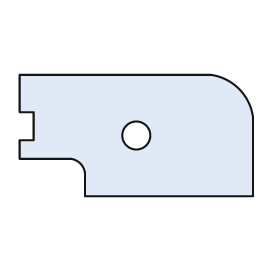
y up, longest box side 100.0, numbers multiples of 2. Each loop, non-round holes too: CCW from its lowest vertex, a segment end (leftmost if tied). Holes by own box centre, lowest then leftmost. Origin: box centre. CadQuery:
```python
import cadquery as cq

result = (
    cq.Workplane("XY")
    .moveTo(-22.0, -26.0)
    .lineTo(50.0, -26.0)
    .lineTo(50.0, 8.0)
    .threePointArc((44.0, 20.0), (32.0, 26.0))
    .lineTo(-50.0, 26.0)
    .lineTo(-50.0, 10.0)
    .lineTo(-44.0, 10.0)
    .lineTo(-44.0, -2.0)
    .lineTo(-50.0, -2.0)
    .lineTo(-50.0, -10.0)
    .lineTo(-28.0, -10.0)
    .threePointArc((-24.0, -12.0), (-22.0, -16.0))
    .close()
    .moveTo(0.0, 0.0)
    .circle(6.0)
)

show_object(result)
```